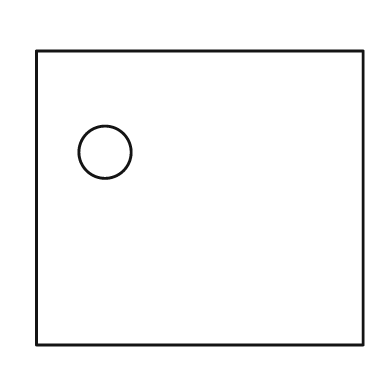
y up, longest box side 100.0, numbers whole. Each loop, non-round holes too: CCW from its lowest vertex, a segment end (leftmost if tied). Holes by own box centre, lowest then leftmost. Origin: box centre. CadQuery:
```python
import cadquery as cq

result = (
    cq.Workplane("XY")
    .moveTo(-50.0, -45.0)
    .lineTo(50.0, -45.0)
    .lineTo(50.0, 45.0)
    .lineTo(-50.0, 45.0)
    .close()
    .moveTo(-29.0, 14.0)
    .circle(8.0)
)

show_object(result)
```